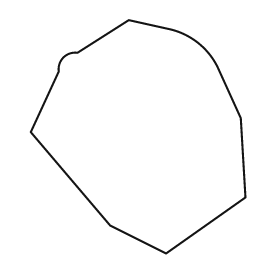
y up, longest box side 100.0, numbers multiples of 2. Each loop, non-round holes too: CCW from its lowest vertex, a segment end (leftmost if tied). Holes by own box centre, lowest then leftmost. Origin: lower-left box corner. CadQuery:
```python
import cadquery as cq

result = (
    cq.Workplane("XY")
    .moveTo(58.0, 0.0)
    .lineTo(92.0, 24.0)
    .lineTo(90.0, 58.0)
    .lineTo(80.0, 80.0)
    .threePointArc((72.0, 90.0), (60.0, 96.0))
    .lineTo(42.0, 100.0)
    .lineTo(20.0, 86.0)
    .threePointArc((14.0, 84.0), (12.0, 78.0))
    .lineTo(0.0, 52.0)
    .lineTo(34.0, 12.0)
    .close()
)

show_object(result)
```